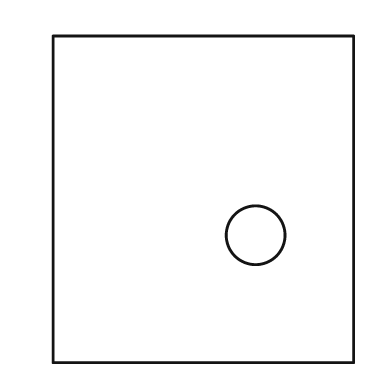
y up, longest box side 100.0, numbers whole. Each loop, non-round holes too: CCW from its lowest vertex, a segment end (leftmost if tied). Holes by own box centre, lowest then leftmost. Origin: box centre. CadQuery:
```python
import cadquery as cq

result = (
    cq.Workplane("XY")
    .moveTo(-46.0, -50.0)
    .lineTo(46.0, -50.0)
    .lineTo(46.0, 50.0)
    .lineTo(-46.0, 50.0)
    .close()
    .moveTo(16.0, -11.0)
    .circle(9.0)
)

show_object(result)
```